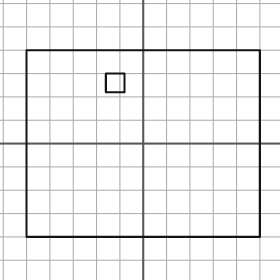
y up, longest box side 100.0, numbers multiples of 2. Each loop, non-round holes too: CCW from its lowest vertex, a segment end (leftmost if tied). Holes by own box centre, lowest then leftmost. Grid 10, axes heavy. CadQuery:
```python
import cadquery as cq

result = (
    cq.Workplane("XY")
    .moveTo(-50.0, -40.0)
    .lineTo(50.0, -40.0)
    .lineTo(50.0, 40.0)
    .lineTo(-50.0, 40.0)
    .close()
    .moveTo(-16.0, 22.0)
    .lineTo(-8.0, 22.0)
    .lineTo(-8.0, 30.0)
    .lineTo(-16.0, 30.0)
    .close()
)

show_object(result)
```